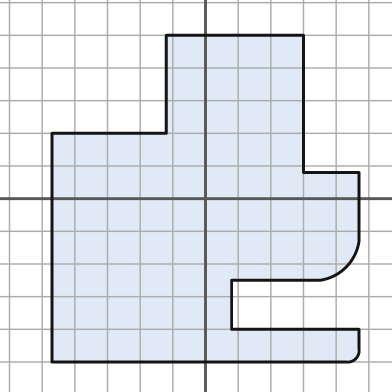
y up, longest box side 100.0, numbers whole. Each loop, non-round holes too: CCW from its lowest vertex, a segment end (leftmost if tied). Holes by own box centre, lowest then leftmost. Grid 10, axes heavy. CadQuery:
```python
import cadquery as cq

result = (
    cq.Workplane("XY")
    .moveTo(-47.0, -50.0)
    .lineTo(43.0, -50.0)
    .threePointArc((46.0, -49.0), (47.0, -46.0))
    .lineTo(47.0, -40.0)
    .lineTo(8.0, -40.0)
    .lineTo(8.0, -25.0)
    .lineTo(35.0, -25.0)
    .threePointArc((43.0, -21.0), (47.0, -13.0))
    .lineTo(47.0, 8.0)
    .lineTo(30.0, 8.0)
    .lineTo(30.0, 50.0)
    .lineTo(-12.0, 50.0)
    .lineTo(-12.0, 20.0)
    .lineTo(-47.0, 20.0)
    .close()
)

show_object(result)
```